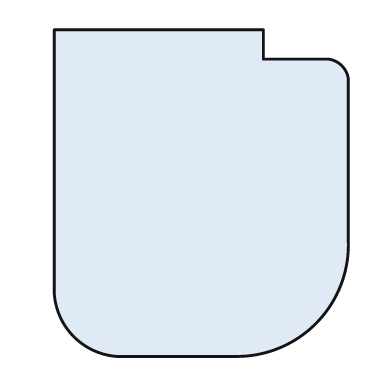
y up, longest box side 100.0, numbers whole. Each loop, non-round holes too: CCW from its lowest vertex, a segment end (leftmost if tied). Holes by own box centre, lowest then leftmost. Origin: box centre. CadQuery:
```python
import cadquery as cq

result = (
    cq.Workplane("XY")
    .moveTo(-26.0, -50.0)
    .lineTo(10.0, -50.0)
    .threePointArc((35.0, -40.0), (45.0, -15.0))
    .lineTo(45.0, 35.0)
    .threePointArc((43.0, 39.0), (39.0, 41.0))
    .lineTo(19.0, 41.0)
    .lineTo(19.0, 50.0)
    .lineTo(-45.0, 50.0)
    .lineTo(-45.0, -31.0)
    .threePointArc((-39.0, -44.0), (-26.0, -50.0))
    .close()
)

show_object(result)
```